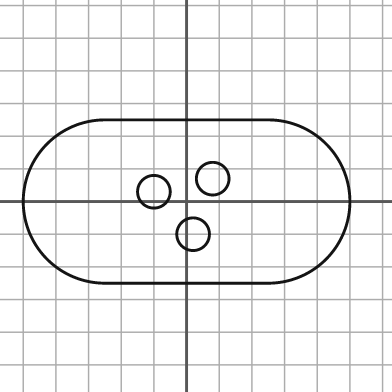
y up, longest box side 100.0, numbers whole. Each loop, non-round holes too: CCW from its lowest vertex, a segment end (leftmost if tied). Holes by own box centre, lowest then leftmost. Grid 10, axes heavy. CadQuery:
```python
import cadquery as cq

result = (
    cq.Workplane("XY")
    .moveTo(-25.0, -25.0)
    .lineTo(25.0, -25.0)
    .threePointArc((50.0, 0.0), (25.0, 25.0))
    .lineTo(-25.0, 25.0)
    .threePointArc((-50.0, 0.0), (-25.0, -25.0))
    .close()
    .moveTo(2.0, -10.0)
    .circle(5.0)
    .moveTo(-10.0, 3.0)
    .circle(5.0)
    .moveTo(8.0, 7.0)
    .circle(5.0)
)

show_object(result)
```